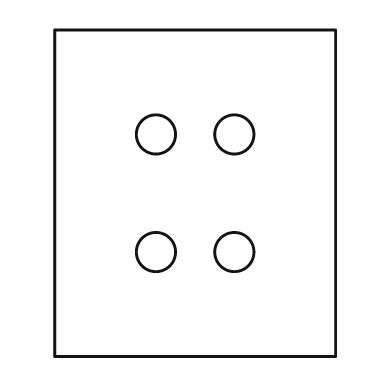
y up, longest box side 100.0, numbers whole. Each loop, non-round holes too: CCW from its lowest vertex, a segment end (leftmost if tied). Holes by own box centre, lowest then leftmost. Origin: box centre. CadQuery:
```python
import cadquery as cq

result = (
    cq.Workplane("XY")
    .moveTo(-43.0, -50.0)
    .lineTo(43.0, -50.0)
    .lineTo(43.0, 50.0)
    .lineTo(-43.0, 50.0)
    .close()
    .moveTo(-12.0, -18.0)
    .circle(6.0)
    .moveTo(12.0, -18.0)
    .circle(6.0)
    .moveTo(-12.0, 18.0)
    .circle(6.0)
    .moveTo(12.0, 18.0)
    .circle(6.0)
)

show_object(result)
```